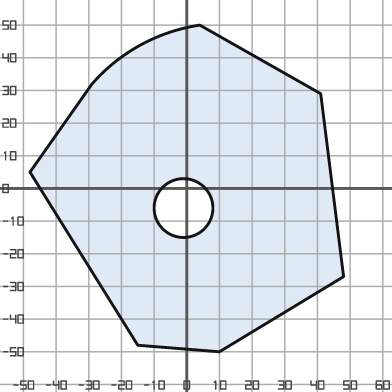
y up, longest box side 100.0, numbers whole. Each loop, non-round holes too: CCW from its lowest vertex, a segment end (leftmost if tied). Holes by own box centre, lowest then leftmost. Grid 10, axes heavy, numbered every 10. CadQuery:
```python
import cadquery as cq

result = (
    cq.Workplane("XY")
    .moveTo(10.0, -50.0)
    .lineTo(48.0, -27.0)
    .lineTo(41.0, 29.0)
    .lineTo(4.0, 50.0)
    .threePointArc((-14.0, 44.0), (-29.0, 32.0))
    .lineTo(-48.0, 5.0)
    .lineTo(-15.0, -48.0)
    .close()
    .moveTo(-1.0, -6.0)
    .circle(9.0)
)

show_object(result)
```